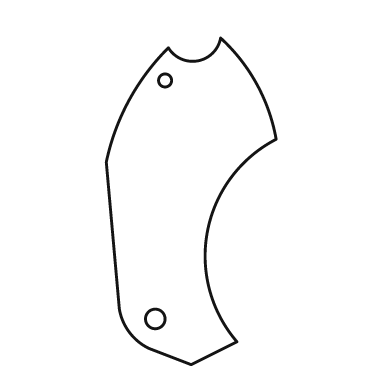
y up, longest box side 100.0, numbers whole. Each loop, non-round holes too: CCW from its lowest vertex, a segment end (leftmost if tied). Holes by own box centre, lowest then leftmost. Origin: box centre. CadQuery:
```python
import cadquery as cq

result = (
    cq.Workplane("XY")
    .moveTo(0.0, -50.0)
    .lineTo(14.0, -43.0)
    .threePointArc((5.0, -9.0), (26.0, 19.0))
    .threePointArc((20.0, 36.0), (9.0, 50.0))
    .threePointArc((2.0, 43.0), (-7.0, 47.0))
    .threePointArc((-19.0, 31.0), (-26.0, 12.0))
    .lineTo(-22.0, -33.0)
    .threePointArc((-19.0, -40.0), (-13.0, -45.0))
    .close()
    .moveTo(-11.0, -36.0)
    .circle(3.0)
    .moveTo(-8.0, 37.0)
    .circle(2.0)
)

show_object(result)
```